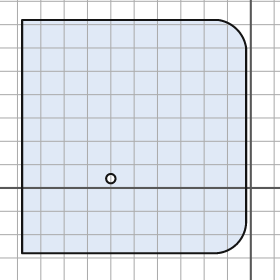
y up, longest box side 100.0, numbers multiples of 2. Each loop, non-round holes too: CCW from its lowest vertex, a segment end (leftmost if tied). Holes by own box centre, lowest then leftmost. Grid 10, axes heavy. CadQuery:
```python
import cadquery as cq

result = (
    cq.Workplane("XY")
    .moveTo(-98.0, -28.0)
    .lineTo(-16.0, -28.0)
    .threePointArc((-6.0, -24.0), (-2.0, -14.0))
    .lineTo(-2.0, 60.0)
    .threePointArc((-6.0, 68.0), (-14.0, 72.0))
    .lineTo(-98.0, 72.0)
    .close()
    .moveTo(-60.0, 4.0)
    .circle(2.0)
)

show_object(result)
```